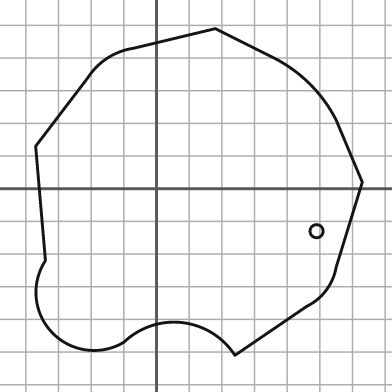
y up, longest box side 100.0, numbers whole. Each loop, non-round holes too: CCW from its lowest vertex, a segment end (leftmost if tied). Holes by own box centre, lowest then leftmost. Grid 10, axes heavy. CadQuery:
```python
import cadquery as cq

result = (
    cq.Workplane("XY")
    .moveTo(24.0, -51.0)
    .lineTo(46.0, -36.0)
    .threePointArc((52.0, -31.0), (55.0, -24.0))
    .lineTo(63.0, 2.0)
    .lineTo(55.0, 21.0)
    .threePointArc((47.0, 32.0), (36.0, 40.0))
    .lineTo(18.0, 49.0)
    .lineTo(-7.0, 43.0)
    .threePointArc((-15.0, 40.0), (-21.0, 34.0))
    .lineTo(-37.0, 13.0)
    .lineTo(-34.0, -22.0)
    .threePointArc((-32.0, -44.0), (-10.0, -47.0))
    .threePointArc((8.0, -41.0), (24.0, -51.0))
    .close()
    .moveTo(49.0, -13.0)
    .circle(2.0)
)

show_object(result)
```